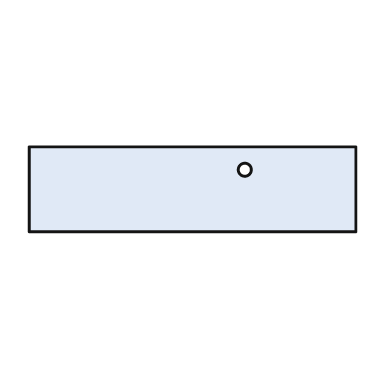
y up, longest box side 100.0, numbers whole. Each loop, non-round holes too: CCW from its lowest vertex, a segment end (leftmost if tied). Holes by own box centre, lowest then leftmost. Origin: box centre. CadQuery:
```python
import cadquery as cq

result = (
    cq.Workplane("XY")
    .moveTo(-50.0, -13.0)
    .lineTo(50.0, -13.0)
    .lineTo(50.0, 13.0)
    .lineTo(-50.0, 13.0)
    .close()
    .moveTo(16.0, 6.0)
    .circle(2.0)
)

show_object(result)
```